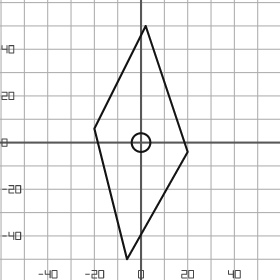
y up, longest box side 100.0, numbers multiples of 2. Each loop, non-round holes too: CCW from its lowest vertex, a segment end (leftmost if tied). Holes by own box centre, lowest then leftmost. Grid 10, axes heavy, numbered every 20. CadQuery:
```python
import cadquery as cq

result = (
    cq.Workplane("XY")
    .moveTo(-6.0, -50.0)
    .lineTo(20.0, -4.0)
    .lineTo(2.0, 50.0)
    .lineTo(-20.0, 6.0)
    .close()
    .moveTo(0.0, 0.0)
    .circle(4.0)
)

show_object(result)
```